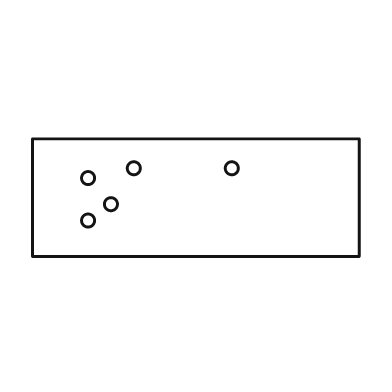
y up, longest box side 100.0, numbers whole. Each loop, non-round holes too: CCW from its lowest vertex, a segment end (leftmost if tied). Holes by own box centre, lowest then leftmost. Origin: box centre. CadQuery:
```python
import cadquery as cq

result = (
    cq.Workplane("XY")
    .moveTo(-50.0, -18.0)
    .lineTo(50.0, -18.0)
    .lineTo(50.0, 18.0)
    .lineTo(-50.0, 18.0)
    .close()
    .moveTo(-33.0, -7.0)
    .circle(2.0)
    .moveTo(-26.0, -2.0)
    .circle(2.0)
    .moveTo(-33.0, 6.0)
    .circle(2.0)
    .moveTo(-19.0, 9.0)
    .circle(2.0)
    .moveTo(11.0, 9.0)
    .circle(2.0)
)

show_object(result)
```